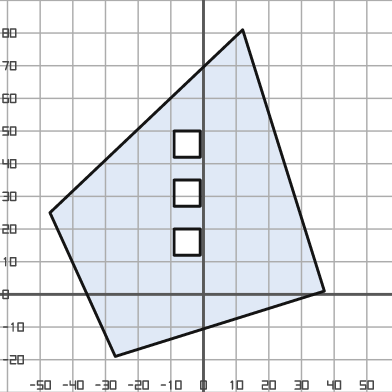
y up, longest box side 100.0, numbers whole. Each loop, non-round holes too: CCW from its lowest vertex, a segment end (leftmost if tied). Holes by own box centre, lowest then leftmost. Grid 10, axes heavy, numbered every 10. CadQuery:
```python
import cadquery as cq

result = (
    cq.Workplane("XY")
    .moveTo(-27.0, -19.0)
    .lineTo(37.0, 1.0)
    .lineTo(12.0, 81.0)
    .lineTo(-47.0, 25.0)
    .close()
    .moveTo(-9.0, 12.0)
    .lineTo(-1.0, 12.0)
    .lineTo(-1.0, 20.0)
    .lineTo(-9.0, 20.0)
    .close()
    .moveTo(-9.0, 27.0)
    .lineTo(-1.0, 27.0)
    .lineTo(-1.0, 35.0)
    .lineTo(-9.0, 35.0)
    .close()
    .moveTo(-9.0, 42.0)
    .lineTo(-1.0, 42.0)
    .lineTo(-1.0, 50.0)
    .lineTo(-9.0, 50.0)
    .close()
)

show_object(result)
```